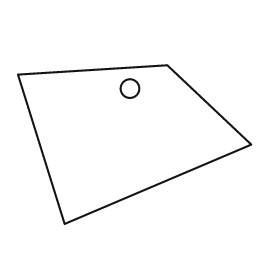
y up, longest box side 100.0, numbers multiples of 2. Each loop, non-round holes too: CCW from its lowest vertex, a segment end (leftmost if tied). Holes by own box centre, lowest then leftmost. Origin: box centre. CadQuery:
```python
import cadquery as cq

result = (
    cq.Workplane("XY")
    .moveTo(-30.0, -34.0)
    .lineTo(50.0, 0.0)
    .lineTo(14.0, 34.0)
    .lineTo(-50.0, 30.0)
    .close()
    .moveTo(-2.0, 24.0)
    .circle(4.0)
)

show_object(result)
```